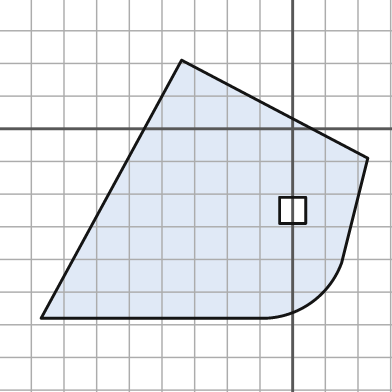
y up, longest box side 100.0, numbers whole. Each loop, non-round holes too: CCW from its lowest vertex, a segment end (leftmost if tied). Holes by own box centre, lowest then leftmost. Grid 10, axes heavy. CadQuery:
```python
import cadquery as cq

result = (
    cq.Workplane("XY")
    .moveTo(-77.0, -58.0)
    .lineTo(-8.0, -58.0)
    .threePointArc((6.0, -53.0), (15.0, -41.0))
    .lineTo(23.0, -9.0)
    .lineTo(-34.0, 21.0)
    .close()
    .moveTo(-4.0, -29.0)
    .lineTo(4.0, -29.0)
    .lineTo(4.0, -21.0)
    .lineTo(-4.0, -21.0)
    .close()
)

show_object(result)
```